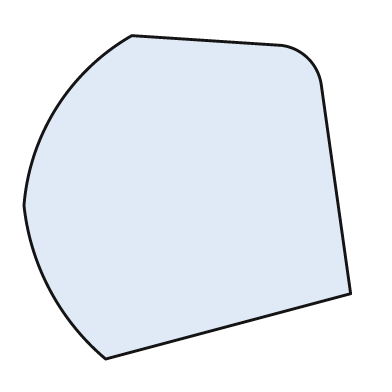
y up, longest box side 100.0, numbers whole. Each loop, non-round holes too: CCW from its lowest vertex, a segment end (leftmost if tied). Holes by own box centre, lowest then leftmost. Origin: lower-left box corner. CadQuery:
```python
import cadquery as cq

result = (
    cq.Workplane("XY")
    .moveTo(25.0, 0.0)
    .lineTo(100.0, 20.0)
    .lineTo(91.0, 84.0)
    .threePointArc((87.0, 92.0), (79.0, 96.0))
    .lineTo(33.0, 99.0)
    .threePointArc((10.0, 77.0), (0.0, 47.0))
    .threePointArc((8.0, 21.0), (25.0, 0.0))
    .close()
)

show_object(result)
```